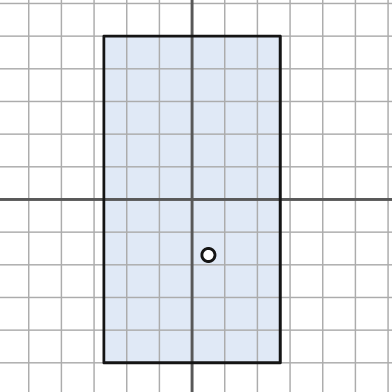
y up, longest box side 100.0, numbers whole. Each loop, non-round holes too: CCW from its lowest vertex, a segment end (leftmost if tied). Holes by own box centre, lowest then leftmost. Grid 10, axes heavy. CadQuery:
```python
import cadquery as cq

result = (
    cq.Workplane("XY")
    .moveTo(-27.0, -50.0)
    .lineTo(27.0, -50.0)
    .lineTo(27.0, 50.0)
    .lineTo(-27.0, 50.0)
    .close()
    .moveTo(5.0, -17.0)
    .circle(2.0)
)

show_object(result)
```